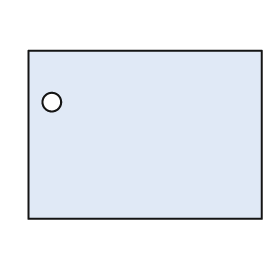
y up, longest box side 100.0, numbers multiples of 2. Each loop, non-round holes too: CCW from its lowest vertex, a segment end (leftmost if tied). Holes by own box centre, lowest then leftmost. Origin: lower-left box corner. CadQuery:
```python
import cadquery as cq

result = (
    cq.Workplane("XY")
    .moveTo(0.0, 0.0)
    .lineTo(100.0, 0.0)
    .lineTo(100.0, 72.0)
    .lineTo(0.0, 72.0)
    .close()
    .moveTo(10.0, 50.0)
    .circle(4.0)
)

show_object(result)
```